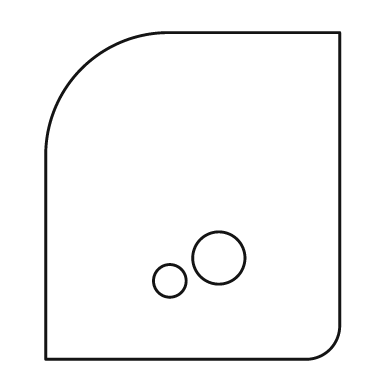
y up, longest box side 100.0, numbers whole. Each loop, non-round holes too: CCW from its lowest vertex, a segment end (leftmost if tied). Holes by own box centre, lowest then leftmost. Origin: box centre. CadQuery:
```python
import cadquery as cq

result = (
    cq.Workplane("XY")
    .moveTo(-45.0, -50.0)
    .lineTo(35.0, -50.0)
    .threePointArc((42.0, -47.0), (45.0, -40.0))
    .lineTo(45.0, 50.0)
    .lineTo(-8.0, 50.0)
    .threePointArc((-34.0, 39.0), (-45.0, 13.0))
    .close()
    .moveTo(-7.0, -26.0)
    .circle(5.0)
    .moveTo(8.0, -19.0)
    .circle(8.0)
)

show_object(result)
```